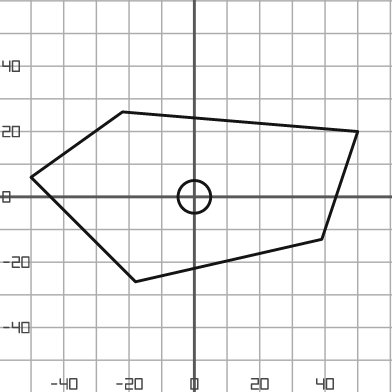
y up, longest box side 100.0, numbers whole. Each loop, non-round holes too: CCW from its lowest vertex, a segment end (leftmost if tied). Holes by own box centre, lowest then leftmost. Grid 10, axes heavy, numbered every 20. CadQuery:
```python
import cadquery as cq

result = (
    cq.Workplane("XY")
    .moveTo(-18.0, -26.0)
    .lineTo(39.0, -13.0)
    .lineTo(50.0, 20.0)
    .lineTo(-22.0, 26.0)
    .lineTo(-50.0, 6.0)
    .close()
    .moveTo(0.0, 0.0)
    .circle(5.0)
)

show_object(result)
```